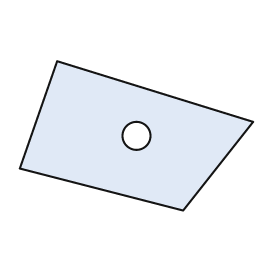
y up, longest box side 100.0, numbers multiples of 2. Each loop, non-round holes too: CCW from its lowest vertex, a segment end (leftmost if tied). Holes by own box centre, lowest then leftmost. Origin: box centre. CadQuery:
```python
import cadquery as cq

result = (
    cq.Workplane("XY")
    .moveTo(20.0, -32.0)
    .lineTo(50.0, 6.0)
    .lineTo(-34.0, 32.0)
    .lineTo(-50.0, -14.0)
    .close()
    .moveTo(0.0, 0.0)
    .circle(6.0)
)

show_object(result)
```